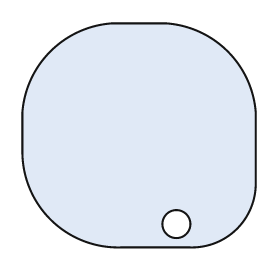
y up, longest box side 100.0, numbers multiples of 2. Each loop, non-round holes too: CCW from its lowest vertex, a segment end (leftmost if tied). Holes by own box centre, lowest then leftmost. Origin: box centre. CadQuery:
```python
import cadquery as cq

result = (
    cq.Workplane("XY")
    .moveTo(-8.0, -48.0)
    .lineTo(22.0, -48.0)
    .threePointArc((42.0, -40.0), (50.0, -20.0))
    .lineTo(50.0, 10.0)
    .threePointArc((38.0, 36.0), (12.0, 48.0))
    .lineTo(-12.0, 48.0)
    .threePointArc((-38.0, 36.0), (-50.0, 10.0))
    .lineTo(-50.0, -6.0)
    .threePointArc((-38.0, -36.0), (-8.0, -48.0))
    .close()
    .moveTo(16.0, -38.0)
    .circle(6.0)
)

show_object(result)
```